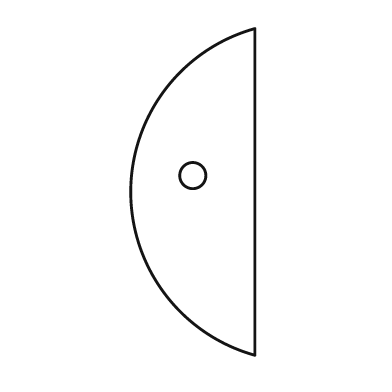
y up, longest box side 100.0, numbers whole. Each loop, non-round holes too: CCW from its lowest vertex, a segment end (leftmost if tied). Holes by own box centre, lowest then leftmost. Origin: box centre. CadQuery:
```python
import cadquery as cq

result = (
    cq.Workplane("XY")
    .moveTo(19.0, -50.0)
    .lineTo(19.0, 50.0)
    .threePointArc((-19.0, 0.0), (19.0, -50.0))
    .close()
    .moveTo(0.0, 5.0)
    .circle(4.0)
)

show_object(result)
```